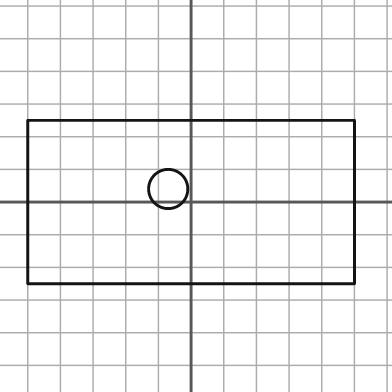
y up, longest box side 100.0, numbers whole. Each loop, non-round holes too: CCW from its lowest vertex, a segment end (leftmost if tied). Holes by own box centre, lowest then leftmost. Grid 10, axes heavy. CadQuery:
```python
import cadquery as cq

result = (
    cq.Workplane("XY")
    .moveTo(-50.0, -25.0)
    .lineTo(50.0, -25.0)
    .lineTo(50.0, 25.0)
    .lineTo(-50.0, 25.0)
    .close()
    .moveTo(-7.0, 4.0)
    .circle(6.0)
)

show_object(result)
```